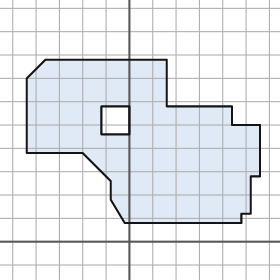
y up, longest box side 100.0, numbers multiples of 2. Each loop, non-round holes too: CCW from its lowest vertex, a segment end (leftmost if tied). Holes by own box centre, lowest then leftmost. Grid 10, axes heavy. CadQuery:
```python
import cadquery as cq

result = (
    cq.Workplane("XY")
    .moveTo(-2.0, 8.0)
    .lineTo(48.0, 8.0)
    .lineTo(48.0, 12.0)
    .lineTo(52.0, 12.0)
    .lineTo(52.0, 28.0)
    .lineTo(56.0, 28.0)
    .lineTo(56.0, 50.0)
    .lineTo(44.0, 50.0)
    .lineTo(44.0, 58.0)
    .lineTo(16.0, 58.0)
    .lineTo(16.0, 78.0)
    .lineTo(-36.0, 78.0)
    .lineTo(-44.0, 70.0)
    .lineTo(-44.0, 38.0)
    .lineTo(-20.0, 38.0)
    .lineTo(-8.0, 26.0)
    .lineTo(-8.0, 18.0)
    .close()
    .moveTo(-12.0, 46.0)
    .lineTo(0.0, 46.0)
    .lineTo(0.0, 58.0)
    .lineTo(-12.0, 58.0)
    .close()
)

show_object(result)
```